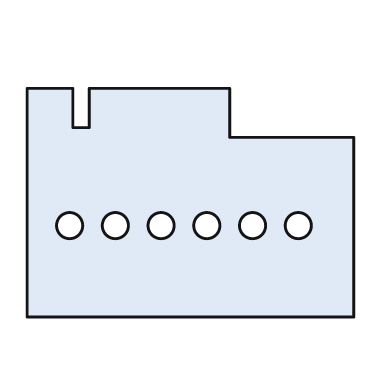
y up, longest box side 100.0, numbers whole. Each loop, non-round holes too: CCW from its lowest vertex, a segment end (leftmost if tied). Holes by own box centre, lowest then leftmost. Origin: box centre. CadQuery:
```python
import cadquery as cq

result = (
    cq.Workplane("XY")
    .moveTo(-50.0, -35.0)
    .lineTo(50.0, -35.0)
    .lineTo(50.0, 20.0)
    .lineTo(12.0, 20.0)
    .lineTo(12.0, 35.0)
    .lineTo(-31.0, 35.0)
    .lineTo(-31.0, 23.0)
    .lineTo(-36.0, 23.0)
    .lineTo(-36.0, 35.0)
    .lineTo(-50.0, 35.0)
    .close()
    .moveTo(-37.0, -7.0)
    .circle(4.0)
    .moveTo(-23.0, -7.0)
    .circle(4.0)
    .moveTo(-9.0, -7.0)
    .circle(4.0)
    .moveTo(5.0, -7.0)
    .circle(4.0)
    .moveTo(19.0, -7.0)
    .circle(4.0)
    .moveTo(33.0, -7.0)
    .circle(4.0)
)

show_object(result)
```